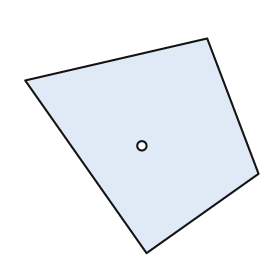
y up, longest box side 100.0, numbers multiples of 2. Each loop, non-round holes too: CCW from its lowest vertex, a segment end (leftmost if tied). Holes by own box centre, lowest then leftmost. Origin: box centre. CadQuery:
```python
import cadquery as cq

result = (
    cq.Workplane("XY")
    .moveTo(2.0, -46.0)
    .lineTo(50.0, -12.0)
    .lineTo(28.0, 46.0)
    .lineTo(-50.0, 28.0)
    .close()
    .moveTo(0.0, 0.0)
    .circle(2.0)
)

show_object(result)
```